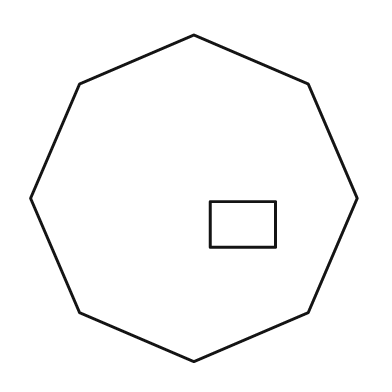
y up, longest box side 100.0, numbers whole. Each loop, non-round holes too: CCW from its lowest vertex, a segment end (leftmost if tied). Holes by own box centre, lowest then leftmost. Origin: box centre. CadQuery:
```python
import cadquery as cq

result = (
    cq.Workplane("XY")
    .moveTo(0.0, -50.0)
    .lineTo(35.0, -35.0)
    .lineTo(50.0, 0.0)
    .lineTo(35.0, 35.0)
    .lineTo(0.0, 50.0)
    .lineTo(-35.0, 35.0)
    .lineTo(-50.0, 0.0)
    .lineTo(-35.0, -35.0)
    .close()
    .moveTo(5.0, -15.0)
    .lineTo(25.0, -15.0)
    .lineTo(25.0, -1.0)
    .lineTo(5.0, -1.0)
    .close()
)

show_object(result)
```